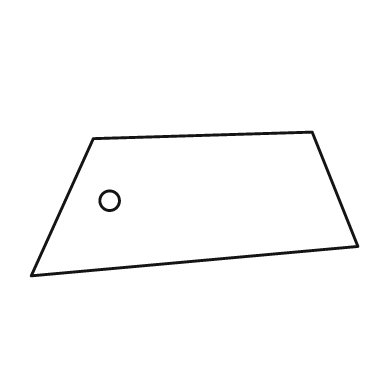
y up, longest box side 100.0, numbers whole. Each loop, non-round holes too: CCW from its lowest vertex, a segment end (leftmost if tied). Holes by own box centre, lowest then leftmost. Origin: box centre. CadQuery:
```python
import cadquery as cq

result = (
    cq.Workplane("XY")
    .moveTo(-50.0, -22.0)
    .lineTo(50.0, -13.0)
    .lineTo(36.0, 22.0)
    .lineTo(-31.0, 20.0)
    .close()
    .moveTo(-26.0, 1.0)
    .circle(3.0)
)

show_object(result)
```